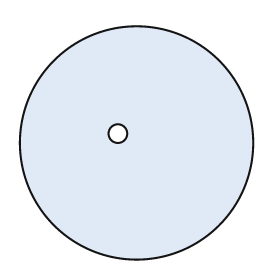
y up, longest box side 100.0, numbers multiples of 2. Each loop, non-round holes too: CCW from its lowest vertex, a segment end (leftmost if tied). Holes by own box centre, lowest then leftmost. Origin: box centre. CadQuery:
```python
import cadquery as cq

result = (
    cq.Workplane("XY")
    .moveTo(0.0, 0.0)
    .circle(50.0)
    .moveTo(-8.0, 4.0)
    .circle(4.0)
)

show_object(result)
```